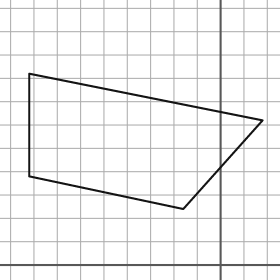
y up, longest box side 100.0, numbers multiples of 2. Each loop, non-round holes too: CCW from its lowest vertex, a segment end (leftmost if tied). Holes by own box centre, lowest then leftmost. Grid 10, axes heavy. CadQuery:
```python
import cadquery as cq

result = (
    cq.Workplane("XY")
    .moveTo(-16.0, 24.0)
    .lineTo(18.0, 62.0)
    .lineTo(-82.0, 82.0)
    .lineTo(-82.0, 38.0)
    .close()
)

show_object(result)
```